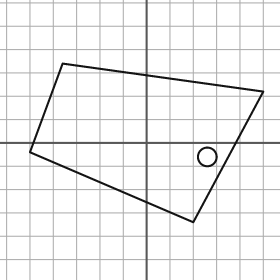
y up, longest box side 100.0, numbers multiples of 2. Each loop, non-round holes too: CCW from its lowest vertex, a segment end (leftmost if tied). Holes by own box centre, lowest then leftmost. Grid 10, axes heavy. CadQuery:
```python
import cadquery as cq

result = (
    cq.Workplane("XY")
    .moveTo(20.0, -34.0)
    .lineTo(50.0, 22.0)
    .lineTo(-36.0, 34.0)
    .lineTo(-50.0, -4.0)
    .close()
    .moveTo(26.0, -6.0)
    .circle(4.0)
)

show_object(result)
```